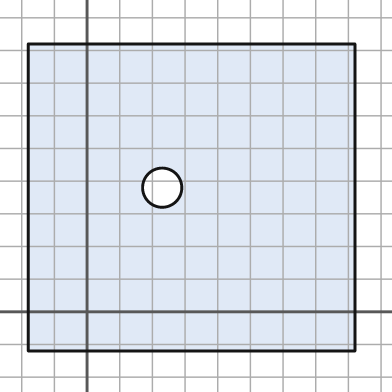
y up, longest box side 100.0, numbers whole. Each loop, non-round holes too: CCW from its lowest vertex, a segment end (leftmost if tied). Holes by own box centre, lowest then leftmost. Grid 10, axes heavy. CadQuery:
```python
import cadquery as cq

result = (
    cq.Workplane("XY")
    .moveTo(-18.0, -12.0)
    .lineTo(82.0, -12.0)
    .lineTo(82.0, 82.0)
    .lineTo(-18.0, 82.0)
    .close()
    .moveTo(23.0, 38.0)
    .circle(6.0)
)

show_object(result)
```